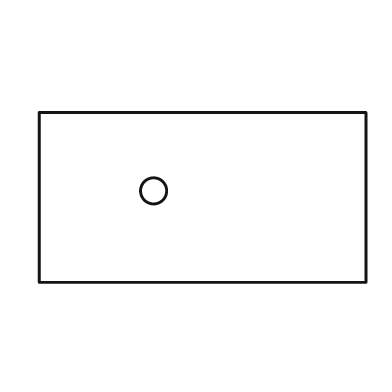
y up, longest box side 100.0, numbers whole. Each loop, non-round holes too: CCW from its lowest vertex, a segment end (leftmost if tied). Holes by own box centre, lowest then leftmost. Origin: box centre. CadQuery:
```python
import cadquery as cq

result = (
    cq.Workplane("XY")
    .moveTo(-50.0, -26.0)
    .lineTo(50.0, -26.0)
    .lineTo(50.0, 26.0)
    .lineTo(-50.0, 26.0)
    .close()
    .moveTo(-15.0, 2.0)
    .circle(4.0)
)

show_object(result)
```